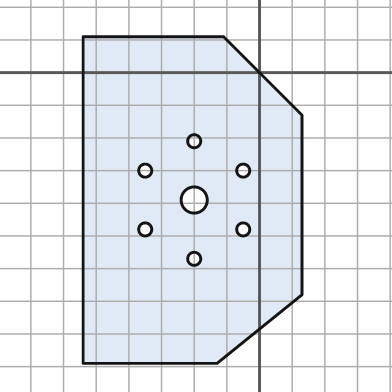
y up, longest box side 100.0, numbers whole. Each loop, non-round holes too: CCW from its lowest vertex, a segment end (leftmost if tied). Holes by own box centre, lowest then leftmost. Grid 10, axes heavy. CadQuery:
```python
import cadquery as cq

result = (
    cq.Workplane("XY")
    .moveTo(-54.0, -89.0)
    .lineTo(-13.0, -89.0)
    .lineTo(13.0, -68.0)
    .lineTo(13.0, -13.0)
    .lineTo(-11.0, 11.0)
    .lineTo(-54.0, 11.0)
    .close()
    .moveTo(-20.0, -57.0)
    .circle(2.0)
    .moveTo(-35.0, -48.0)
    .circle(2.0)
    .moveTo(-5.0, -48.0)
    .circle(2.0)
    .moveTo(-20.0, -39.0)
    .circle(4.0)
    .moveTo(-35.0, -30.0)
    .circle(2.0)
    .moveTo(-5.0, -30.0)
    .circle(2.0)
    .moveTo(-20.0, -21.0)
    .circle(2.0)
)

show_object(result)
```